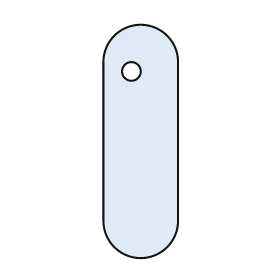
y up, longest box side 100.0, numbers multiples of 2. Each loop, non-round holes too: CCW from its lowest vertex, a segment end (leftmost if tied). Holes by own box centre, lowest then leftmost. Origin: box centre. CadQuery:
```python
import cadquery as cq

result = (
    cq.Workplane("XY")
    .moveTo(-16.0, -34.0)
    .threePointArc((0.0, -50.0), (16.0, -34.0))
    .lineTo(16.0, 34.0)
    .threePointArc((0.0, 50.0), (-16.0, 34.0))
    .close()
    .moveTo(-4.0, 30.0)
    .circle(4.0)
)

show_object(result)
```